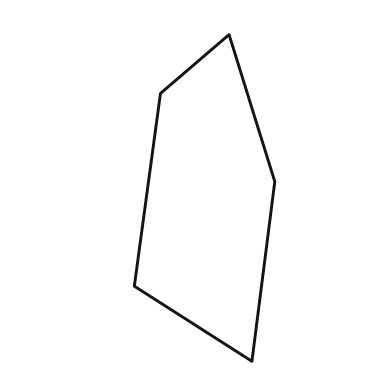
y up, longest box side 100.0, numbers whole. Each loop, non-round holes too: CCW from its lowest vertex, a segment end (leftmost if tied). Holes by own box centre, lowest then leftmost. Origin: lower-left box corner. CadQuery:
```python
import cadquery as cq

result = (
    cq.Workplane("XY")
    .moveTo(36.0, 0.0)
    .lineTo(43.0, 55.0)
    .lineTo(29.0, 100.0)
    .lineTo(8.0, 82.0)
    .lineTo(0.0, 23.0)
    .close()
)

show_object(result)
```